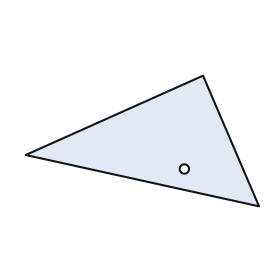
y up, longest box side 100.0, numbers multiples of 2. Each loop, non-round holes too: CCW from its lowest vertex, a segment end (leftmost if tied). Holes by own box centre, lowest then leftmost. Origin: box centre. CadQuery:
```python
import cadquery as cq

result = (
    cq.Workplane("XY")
    .moveTo(50.0, -28.0)
    .lineTo(26.0, 28.0)
    .lineTo(-50.0, -6.0)
    .close()
    .moveTo(18.0, -12.0)
    .circle(2.0)
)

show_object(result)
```